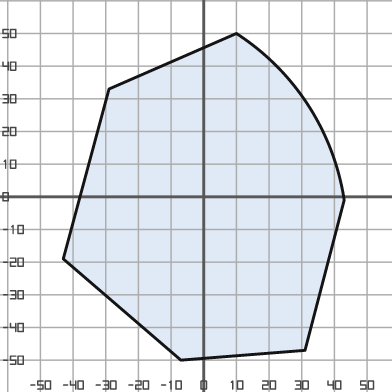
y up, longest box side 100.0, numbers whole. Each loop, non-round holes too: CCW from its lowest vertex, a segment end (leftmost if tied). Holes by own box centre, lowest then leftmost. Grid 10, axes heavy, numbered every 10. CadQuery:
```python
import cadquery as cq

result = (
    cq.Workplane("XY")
    .moveTo(-7.0, -50.0)
    .lineTo(31.0, -47.0)
    .lineTo(43.0, -1.0)
    .threePointArc((32.0, 28.0), (10.0, 50.0))
    .lineTo(-29.0, 33.0)
    .lineTo(-43.0, -19.0)
    .close()
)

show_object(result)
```